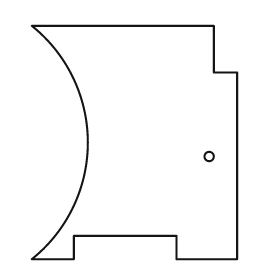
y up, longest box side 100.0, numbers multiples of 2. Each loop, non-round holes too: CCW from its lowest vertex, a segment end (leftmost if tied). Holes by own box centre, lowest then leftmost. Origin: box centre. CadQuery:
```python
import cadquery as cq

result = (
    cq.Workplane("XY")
    .moveTo(-44.0, -50.0)
    .lineTo(-26.0, -50.0)
    .lineTo(-26.0, -40.0)
    .lineTo(18.0, -40.0)
    .lineTo(18.0, -50.0)
    .lineTo(44.0, -50.0)
    .lineTo(44.0, 30.0)
    .lineTo(34.0, 30.0)
    .lineTo(34.0, 50.0)
    .lineTo(-44.0, 50.0)
    .threePointArc((-20.0, 0.0), (-44.0, -50.0))
    .close()
    .moveTo(32.0, -6.0)
    .circle(2.0)
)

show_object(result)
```